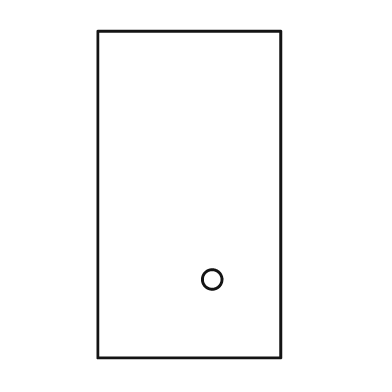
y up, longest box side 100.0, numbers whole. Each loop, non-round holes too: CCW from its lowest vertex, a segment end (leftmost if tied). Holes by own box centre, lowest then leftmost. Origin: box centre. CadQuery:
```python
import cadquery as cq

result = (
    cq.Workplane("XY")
    .moveTo(-28.0, -50.0)
    .lineTo(28.0, -50.0)
    .lineTo(28.0, 50.0)
    .lineTo(-28.0, 50.0)
    .close()
    .moveTo(7.0, -26.0)
    .circle(3.0)
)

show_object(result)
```